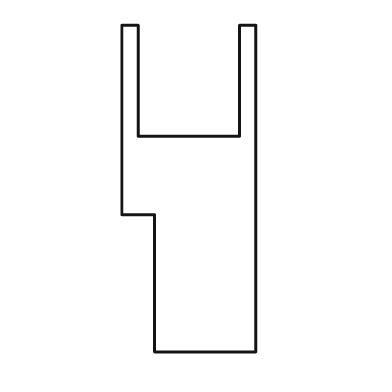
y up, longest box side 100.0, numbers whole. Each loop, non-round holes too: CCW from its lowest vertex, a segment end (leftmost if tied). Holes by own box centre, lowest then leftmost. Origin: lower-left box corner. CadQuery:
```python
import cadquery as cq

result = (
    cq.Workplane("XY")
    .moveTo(10.0, 0.0)
    .lineTo(41.0, 0.0)
    .lineTo(41.0, 100.0)
    .lineTo(36.0, 100.0)
    .lineTo(36.0, 66.0)
    .lineTo(5.0, 66.0)
    .lineTo(5.0, 100.0)
    .lineTo(0.0, 100.0)
    .lineTo(0.0, 42.0)
    .lineTo(10.0, 42.0)
    .close()
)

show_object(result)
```